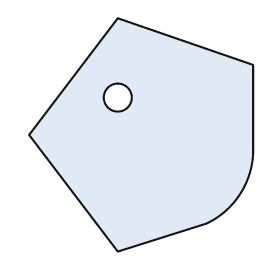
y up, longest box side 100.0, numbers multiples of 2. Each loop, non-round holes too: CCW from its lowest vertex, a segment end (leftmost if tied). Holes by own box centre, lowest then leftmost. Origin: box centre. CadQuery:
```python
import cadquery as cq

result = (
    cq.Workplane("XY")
    .moveTo(-10.0, -50.0)
    .lineTo(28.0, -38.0)
    .threePointArc((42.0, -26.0), (48.0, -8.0))
    .lineTo(48.0, 30.0)
    .lineTo(-10.0, 50.0)
    .lineTo(-48.0, 0.0)
    .close()
    .moveTo(-10.0, 16.0)
    .circle(6.0)
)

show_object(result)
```